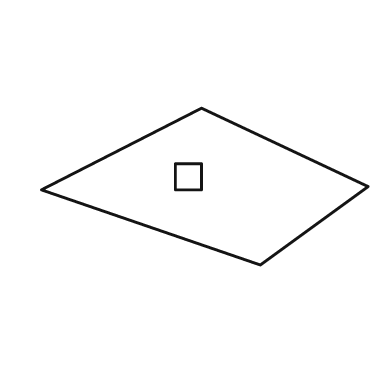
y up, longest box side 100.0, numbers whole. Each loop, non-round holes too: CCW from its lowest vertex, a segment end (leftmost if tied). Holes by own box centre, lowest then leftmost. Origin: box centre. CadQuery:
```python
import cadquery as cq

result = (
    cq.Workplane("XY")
    .moveTo(17.0, -24.0)
    .lineTo(50.0, 0.0)
    .lineTo(-1.0, 24.0)
    .lineTo(-50.0, -1.0)
    .close()
    .moveTo(-9.0, -1.0)
    .lineTo(-1.0, -1.0)
    .lineTo(-1.0, 7.0)
    .lineTo(-9.0, 7.0)
    .close()
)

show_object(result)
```